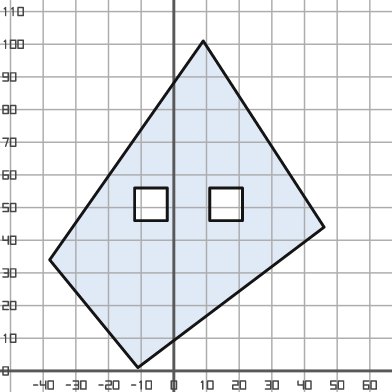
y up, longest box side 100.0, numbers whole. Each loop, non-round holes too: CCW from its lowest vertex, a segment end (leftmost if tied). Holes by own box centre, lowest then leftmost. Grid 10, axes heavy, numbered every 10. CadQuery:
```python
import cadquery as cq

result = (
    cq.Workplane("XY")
    .moveTo(-11.0, 1.0)
    .lineTo(46.0, 44.0)
    .lineTo(9.0, 101.0)
    .lineTo(-38.0, 34.0)
    .close()
    .moveTo(-12.0, 46.0)
    .lineTo(-2.0, 46.0)
    .lineTo(-2.0, 56.0)
    .lineTo(-12.0, 56.0)
    .close()
    .moveTo(11.0, 46.0)
    .lineTo(21.0, 46.0)
    .lineTo(21.0, 56.0)
    .lineTo(11.0, 56.0)
    .close()
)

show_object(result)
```